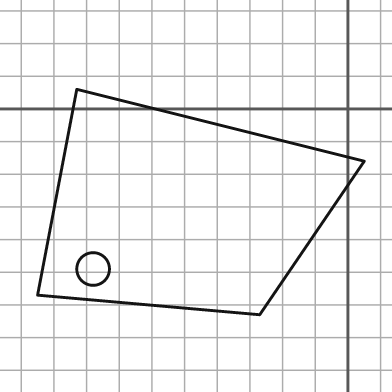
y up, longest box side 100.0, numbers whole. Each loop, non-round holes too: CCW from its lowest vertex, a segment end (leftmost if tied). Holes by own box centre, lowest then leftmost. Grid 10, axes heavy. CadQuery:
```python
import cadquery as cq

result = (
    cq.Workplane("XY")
    .moveTo(-27.0, -63.0)
    .lineTo(5.0, -16.0)
    .lineTo(-83.0, 6.0)
    .lineTo(-95.0, -57.0)
    .close()
    .moveTo(-78.0, -49.0)
    .circle(5.0)
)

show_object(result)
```